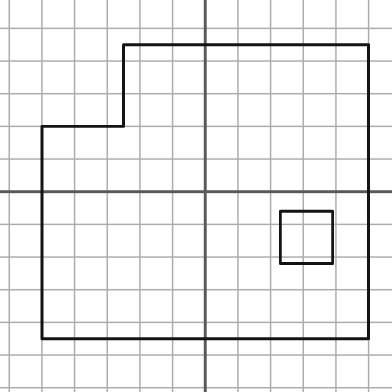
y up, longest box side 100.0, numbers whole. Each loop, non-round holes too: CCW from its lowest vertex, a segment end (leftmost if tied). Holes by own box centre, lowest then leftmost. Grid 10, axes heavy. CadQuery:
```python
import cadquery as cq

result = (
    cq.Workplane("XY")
    .moveTo(-50.0, -45.0)
    .lineTo(50.0, -45.0)
    .lineTo(50.0, 45.0)
    .lineTo(-25.0, 45.0)
    .lineTo(-25.0, 20.0)
    .lineTo(-50.0, 20.0)
    .close()
    .moveTo(23.0, -22.0)
    .lineTo(39.0, -22.0)
    .lineTo(39.0, -6.0)
    .lineTo(23.0, -6.0)
    .close()
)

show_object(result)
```